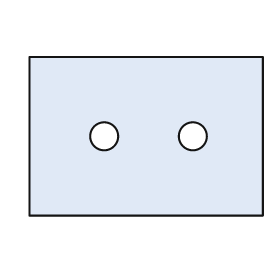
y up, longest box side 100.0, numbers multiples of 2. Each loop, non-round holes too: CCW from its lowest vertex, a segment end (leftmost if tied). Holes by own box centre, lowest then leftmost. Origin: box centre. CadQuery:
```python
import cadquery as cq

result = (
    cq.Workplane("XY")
    .moveTo(-50.0, -34.0)
    .lineTo(50.0, -34.0)
    .lineTo(50.0, 34.0)
    .lineTo(-50.0, 34.0)
    .close()
    .moveTo(-18.0, 0.0)
    .circle(6.0)
    .moveTo(20.0, 0.0)
    .circle(6.0)
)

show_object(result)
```